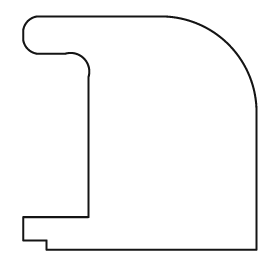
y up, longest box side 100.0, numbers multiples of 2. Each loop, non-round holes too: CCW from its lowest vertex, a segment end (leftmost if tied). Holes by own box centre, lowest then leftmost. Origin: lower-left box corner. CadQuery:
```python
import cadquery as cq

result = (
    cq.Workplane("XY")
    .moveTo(10.0, 0.0)
    .lineTo(100.0, 0.0)
    .lineTo(100.0, 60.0)
    .threePointArc((88.0, 88.0), (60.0, 100.0))
    .lineTo(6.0, 100.0)
    .threePointArc((2.0, 98.0), (0.0, 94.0))
    .lineTo(0.0, 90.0)
    .threePointArc((2.0, 86.0), (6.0, 84.0))
    .lineTo(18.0, 84.0)
    .threePointArc((26.0, 82.0), (28.0, 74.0))
    .lineTo(28.0, 14.0)
    .lineTo(0.0, 14.0)
    .lineTo(0.0, 4.0)
    .lineTo(10.0, 4.0)
    .close()
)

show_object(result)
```